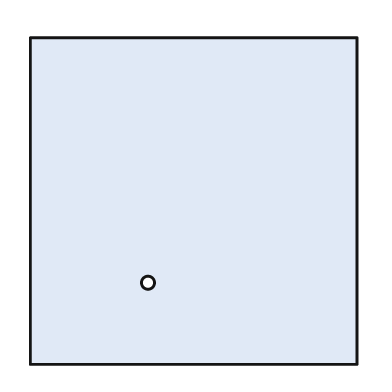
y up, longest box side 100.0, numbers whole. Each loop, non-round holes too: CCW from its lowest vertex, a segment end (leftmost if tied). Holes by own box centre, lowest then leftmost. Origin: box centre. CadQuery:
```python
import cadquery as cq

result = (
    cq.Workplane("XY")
    .moveTo(-50.0, -50.0)
    .lineTo(50.0, -50.0)
    .lineTo(50.0, 50.0)
    .lineTo(-50.0, 50.0)
    .close()
    .moveTo(-14.0, -25.0)
    .circle(2.0)
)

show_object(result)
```